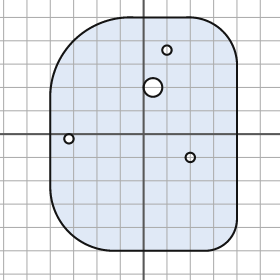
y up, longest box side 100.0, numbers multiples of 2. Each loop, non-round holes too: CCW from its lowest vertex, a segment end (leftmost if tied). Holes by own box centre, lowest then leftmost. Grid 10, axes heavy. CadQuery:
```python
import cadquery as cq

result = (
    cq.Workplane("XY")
    .moveTo(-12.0, -50.0)
    .lineTo(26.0, -50.0)
    .threePointArc((36.0, -46.0), (40.0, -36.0))
    .lineTo(40.0, 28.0)
    .threePointArc((34.0, 44.0), (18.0, 50.0))
    .lineTo(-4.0, 50.0)
    .threePointArc((-30.0, 40.0), (-40.0, 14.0))
    .lineTo(-40.0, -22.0)
    .threePointArc((-32.0, -42.0), (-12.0, -50.0))
    .close()
    .moveTo(20.0, -10.0)
    .circle(2.0)
    .moveTo(-32.0, -2.0)
    .circle(2.0)
    .moveTo(4.0, 20.0)
    .circle(4.0)
    .moveTo(10.0, 36.0)
    .circle(2.0)
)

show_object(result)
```